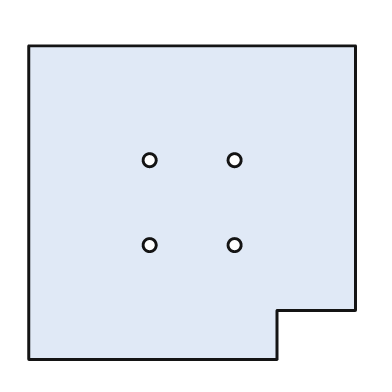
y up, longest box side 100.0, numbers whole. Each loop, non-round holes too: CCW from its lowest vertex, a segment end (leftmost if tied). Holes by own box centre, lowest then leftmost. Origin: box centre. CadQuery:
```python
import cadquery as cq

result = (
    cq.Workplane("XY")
    .moveTo(-50.0, -48.0)
    .lineTo(26.0, -48.0)
    .lineTo(26.0, -33.0)
    .lineTo(50.0, -33.0)
    .lineTo(50.0, 48.0)
    .lineTo(-50.0, 48.0)
    .close()
    .moveTo(-13.0, -13.0)
    .circle(2.0)
    .moveTo(13.0, -13.0)
    .circle(2.0)
    .moveTo(-13.0, 13.0)
    .circle(2.0)
    .moveTo(13.0, 13.0)
    .circle(2.0)
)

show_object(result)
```